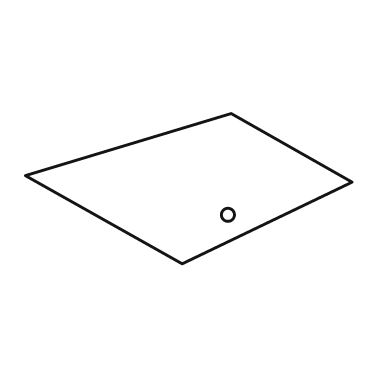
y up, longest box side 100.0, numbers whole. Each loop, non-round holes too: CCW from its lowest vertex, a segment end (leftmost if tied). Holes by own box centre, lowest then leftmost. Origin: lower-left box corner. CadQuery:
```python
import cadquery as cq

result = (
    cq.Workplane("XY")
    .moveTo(48.0, 0.0)
    .lineTo(100.0, 25.0)
    .lineTo(63.0, 46.0)
    .lineTo(0.0, 27.0)
    .close()
    .moveTo(62.0, 15.0)
    .circle(2.0)
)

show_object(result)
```